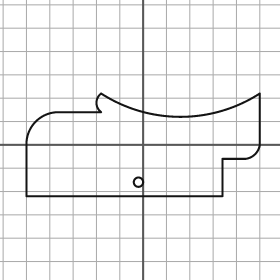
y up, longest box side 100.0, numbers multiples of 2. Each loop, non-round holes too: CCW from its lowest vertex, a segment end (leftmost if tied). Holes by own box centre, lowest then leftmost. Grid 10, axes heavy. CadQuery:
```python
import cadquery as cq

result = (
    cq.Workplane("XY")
    .moveTo(-50.0, -22.0)
    .lineTo(34.0, -22.0)
    .lineTo(34.0, -6.0)
    .lineTo(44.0, -6.0)
    .threePointArc((48.0, -4.0), (50.0, 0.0))
    .lineTo(50.0, 22.0)
    .threePointArc((16.0, 12.0), (-18.0, 22.0))
    .threePointArc((-20.0, 18.0), (-18.0, 14.0))
    .lineTo(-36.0, 14.0)
    .threePointArc((-46.0, 10.0), (-50.0, 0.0))
    .close()
    .moveTo(-2.0, -16.0)
    .circle(2.0)
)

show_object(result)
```